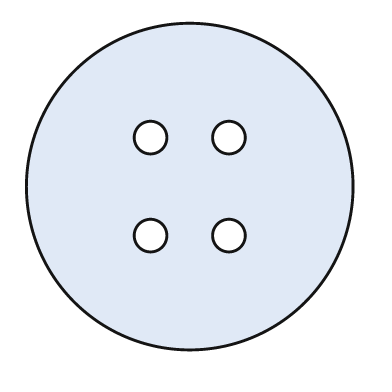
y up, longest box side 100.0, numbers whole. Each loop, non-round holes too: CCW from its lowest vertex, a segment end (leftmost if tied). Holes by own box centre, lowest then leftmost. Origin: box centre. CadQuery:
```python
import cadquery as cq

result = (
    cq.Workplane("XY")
    .moveTo(0.0, 0.0)
    .circle(50.0)
    .moveTo(-12.0, -15.0)
    .circle(5.0)
    .moveTo(12.0, -15.0)
    .circle(5.0)
    .moveTo(-12.0, 15.0)
    .circle(5.0)
    .moveTo(12.0, 15.0)
    .circle(5.0)
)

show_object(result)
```